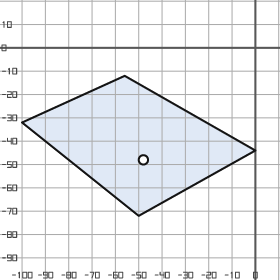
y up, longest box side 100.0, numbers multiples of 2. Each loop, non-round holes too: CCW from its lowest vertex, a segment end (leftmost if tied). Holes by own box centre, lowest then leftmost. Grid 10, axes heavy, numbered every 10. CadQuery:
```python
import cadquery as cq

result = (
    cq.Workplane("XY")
    .moveTo(-50.0, -72.0)
    .lineTo(0.0, -44.0)
    .lineTo(-56.0, -12.0)
    .lineTo(-100.0, -32.0)
    .close()
    .moveTo(-48.0, -48.0)
    .circle(2.0)
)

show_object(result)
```